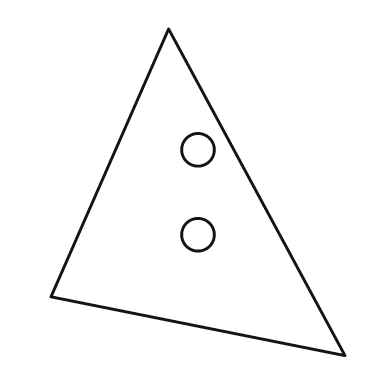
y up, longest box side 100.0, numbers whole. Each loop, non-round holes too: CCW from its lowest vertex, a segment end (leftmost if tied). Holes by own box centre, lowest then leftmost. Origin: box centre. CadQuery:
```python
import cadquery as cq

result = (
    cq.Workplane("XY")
    .moveTo(45.0, -50.0)
    .lineTo(-9.0, 50.0)
    .lineTo(-45.0, -32.0)
    .close()
    .moveTo(0.0, -13.0)
    .circle(5.0)
    .moveTo(0.0, 13.0)
    .circle(5.0)
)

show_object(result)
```